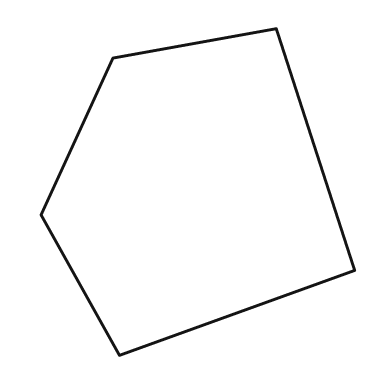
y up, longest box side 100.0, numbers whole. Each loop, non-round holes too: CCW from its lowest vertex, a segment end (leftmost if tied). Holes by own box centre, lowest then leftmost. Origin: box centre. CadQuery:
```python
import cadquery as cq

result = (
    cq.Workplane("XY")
    .moveTo(-24.0, -50.0)
    .lineTo(48.0, -24.0)
    .lineTo(24.0, 50.0)
    .lineTo(-26.0, 41.0)
    .lineTo(-48.0, -7.0)
    .close()
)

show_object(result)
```